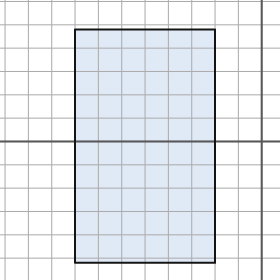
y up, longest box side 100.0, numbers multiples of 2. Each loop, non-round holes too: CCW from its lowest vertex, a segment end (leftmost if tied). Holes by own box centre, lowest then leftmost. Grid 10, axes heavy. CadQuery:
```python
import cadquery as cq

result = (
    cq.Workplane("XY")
    .moveTo(-80.0, -52.0)
    .lineTo(-20.0, -52.0)
    .lineTo(-20.0, 48.0)
    .lineTo(-80.0, 48.0)
    .close()
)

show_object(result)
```